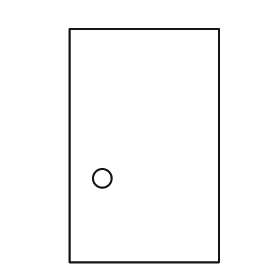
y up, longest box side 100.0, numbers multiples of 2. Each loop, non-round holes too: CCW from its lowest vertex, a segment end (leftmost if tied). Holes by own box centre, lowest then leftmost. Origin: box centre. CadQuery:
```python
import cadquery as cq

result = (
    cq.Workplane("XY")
    .moveTo(-32.0, -50.0)
    .lineTo(32.0, -50.0)
    .lineTo(32.0, 50.0)
    .lineTo(-32.0, 50.0)
    .close()
    .moveTo(-18.0, -14.0)
    .circle(4.0)
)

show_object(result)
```